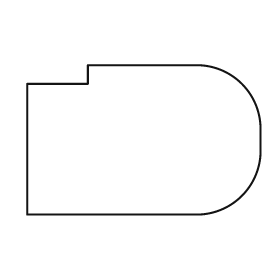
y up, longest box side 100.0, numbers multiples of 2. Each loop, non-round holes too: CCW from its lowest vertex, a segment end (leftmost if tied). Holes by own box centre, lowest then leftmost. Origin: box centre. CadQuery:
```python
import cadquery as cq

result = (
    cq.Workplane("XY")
    .moveTo(-50.0, -32.0)
    .lineTo(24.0, -32.0)
    .threePointArc((42.0, -24.0), (50.0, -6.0))
    .lineTo(50.0, 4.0)
    .threePointArc((42.0, 24.0), (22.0, 32.0))
    .lineTo(-24.0, 32.0)
    .lineTo(-24.0, 24.0)
    .lineTo(-50.0, 24.0)
    .close()
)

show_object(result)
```